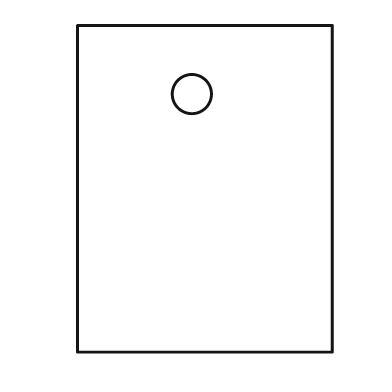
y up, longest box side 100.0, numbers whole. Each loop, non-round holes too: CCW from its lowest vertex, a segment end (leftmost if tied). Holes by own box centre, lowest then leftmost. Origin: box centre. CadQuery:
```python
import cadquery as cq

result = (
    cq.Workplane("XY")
    .moveTo(-39.0, -50.0)
    .lineTo(39.0, -50.0)
    .lineTo(39.0, 50.0)
    .lineTo(-39.0, 50.0)
    .close()
    .moveTo(-4.0, 29.0)
    .circle(6.0)
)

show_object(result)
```